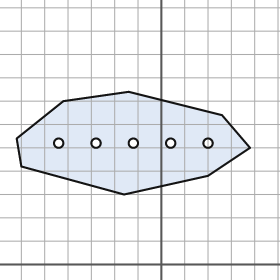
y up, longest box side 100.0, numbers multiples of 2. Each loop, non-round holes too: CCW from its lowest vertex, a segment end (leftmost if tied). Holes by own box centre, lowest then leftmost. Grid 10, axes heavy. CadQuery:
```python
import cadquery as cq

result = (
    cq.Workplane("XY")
    .moveTo(-16.0, 30.0)
    .lineTo(20.0, 38.0)
    .lineTo(38.0, 50.0)
    .lineTo(26.0, 64.0)
    .lineTo(-14.0, 74.0)
    .lineTo(-42.0, 70.0)
    .lineTo(-62.0, 54.0)
    .lineTo(-60.0, 42.0)
    .close()
    .moveTo(-44.0, 52.0)
    .circle(2.0)
    .moveTo(-28.0, 52.0)
    .circle(2.0)
    .moveTo(-12.0, 52.0)
    .circle(2.0)
    .moveTo(4.0, 52.0)
    .circle(2.0)
    .moveTo(20.0, 52.0)
    .circle(2.0)
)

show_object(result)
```